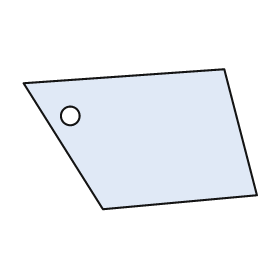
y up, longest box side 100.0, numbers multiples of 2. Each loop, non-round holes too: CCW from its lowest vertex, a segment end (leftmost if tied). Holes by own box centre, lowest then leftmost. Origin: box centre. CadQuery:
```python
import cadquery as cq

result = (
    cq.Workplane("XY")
    .moveTo(-16.0, -30.0)
    .lineTo(50.0, -24.0)
    .lineTo(36.0, 30.0)
    .lineTo(-50.0, 24.0)
    .close()
    .moveTo(-30.0, 10.0)
    .circle(4.0)
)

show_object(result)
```